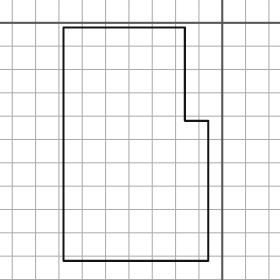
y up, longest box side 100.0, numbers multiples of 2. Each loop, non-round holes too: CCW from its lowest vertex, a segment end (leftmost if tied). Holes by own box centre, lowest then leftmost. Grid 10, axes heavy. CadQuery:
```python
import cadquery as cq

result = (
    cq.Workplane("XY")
    .moveTo(-68.0, -102.0)
    .lineTo(-6.0, -102.0)
    .lineTo(-6.0, -42.0)
    .lineTo(-16.0, -42.0)
    .lineTo(-16.0, -2.0)
    .lineTo(-68.0, -2.0)
    .close()
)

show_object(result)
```